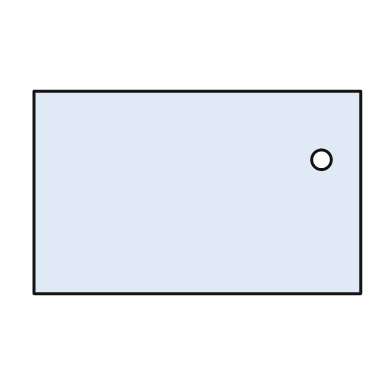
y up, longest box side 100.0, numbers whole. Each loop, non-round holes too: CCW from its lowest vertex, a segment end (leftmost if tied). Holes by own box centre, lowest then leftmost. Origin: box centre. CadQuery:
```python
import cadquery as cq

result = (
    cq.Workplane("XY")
    .moveTo(-50.0, -31.0)
    .lineTo(50.0, -31.0)
    .lineTo(50.0, 31.0)
    .lineTo(-50.0, 31.0)
    .close()
    .moveTo(38.0, 10.0)
    .circle(3.0)
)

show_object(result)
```